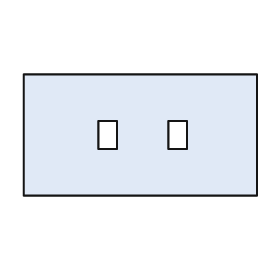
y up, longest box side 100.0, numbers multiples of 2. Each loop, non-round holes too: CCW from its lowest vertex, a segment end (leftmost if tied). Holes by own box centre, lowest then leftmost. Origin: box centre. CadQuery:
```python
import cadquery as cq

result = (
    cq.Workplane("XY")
    .moveTo(-50.0, -26.0)
    .lineTo(50.0, -26.0)
    .lineTo(50.0, 26.0)
    .lineTo(-50.0, 26.0)
    .close()
    .moveTo(-18.0, -6.0)
    .lineTo(-10.0, -6.0)
    .lineTo(-10.0, 6.0)
    .lineTo(-18.0, 6.0)
    .close()
    .moveTo(12.0, -6.0)
    .lineTo(20.0, -6.0)
    .lineTo(20.0, 6.0)
    .lineTo(12.0, 6.0)
    .close()
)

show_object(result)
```